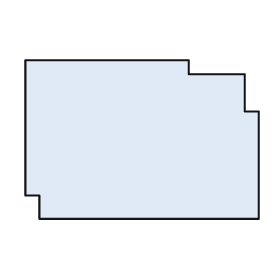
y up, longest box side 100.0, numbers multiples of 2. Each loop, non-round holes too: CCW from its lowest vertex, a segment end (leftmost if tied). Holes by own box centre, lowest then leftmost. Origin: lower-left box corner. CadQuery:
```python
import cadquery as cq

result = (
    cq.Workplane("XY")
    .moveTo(6.0, 0.0)
    .lineTo(100.0, 0.0)
    .lineTo(100.0, 46.0)
    .lineTo(94.0, 46.0)
    .lineTo(94.0, 62.0)
    .lineTo(70.0, 62.0)
    .lineTo(70.0, 68.0)
    .lineTo(0.0, 68.0)
    .lineTo(0.0, 10.0)
    .lineTo(6.0, 10.0)
    .close()
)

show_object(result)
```